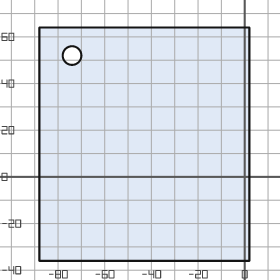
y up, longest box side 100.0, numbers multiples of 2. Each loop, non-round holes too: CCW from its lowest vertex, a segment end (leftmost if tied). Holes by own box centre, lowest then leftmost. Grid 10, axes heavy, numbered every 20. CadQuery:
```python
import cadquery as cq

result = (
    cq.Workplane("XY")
    .moveTo(-88.0, -36.0)
    .lineTo(2.0, -36.0)
    .lineTo(2.0, 64.0)
    .lineTo(-88.0, 64.0)
    .close()
    .moveTo(-74.0, 52.0)
    .circle(4.0)
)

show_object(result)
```